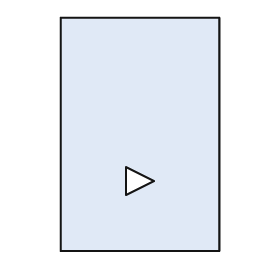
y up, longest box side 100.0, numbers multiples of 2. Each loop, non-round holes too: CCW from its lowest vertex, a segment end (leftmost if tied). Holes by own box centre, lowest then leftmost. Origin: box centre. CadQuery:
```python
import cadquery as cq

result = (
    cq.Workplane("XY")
    .moveTo(-34.0, -50.0)
    .lineTo(34.0, -50.0)
    .lineTo(34.0, 50.0)
    .lineTo(-34.0, 50.0)
    .close()
    .moveTo(-6.0, -26.0)
    .lineTo(6.0, -20.0)
    .lineTo(-6.0, -14.0)
    .close()
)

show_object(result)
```